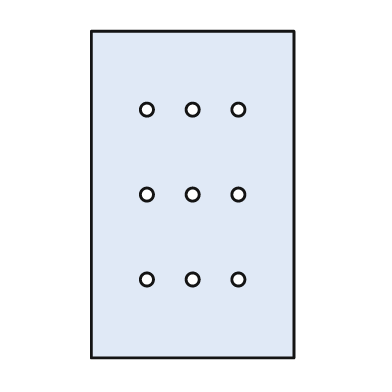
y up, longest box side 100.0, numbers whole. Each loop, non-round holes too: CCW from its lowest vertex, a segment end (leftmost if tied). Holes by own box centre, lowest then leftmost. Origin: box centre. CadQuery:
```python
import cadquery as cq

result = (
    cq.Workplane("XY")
    .moveTo(-31.0, -50.0)
    .lineTo(31.0, -50.0)
    .lineTo(31.0, 50.0)
    .lineTo(-31.0, 50.0)
    .close()
    .moveTo(-14.0, -26.0)
    .circle(2.0)
    .moveTo(0.0, -26.0)
    .circle(2.0)
    .moveTo(14.0, -26.0)
    .circle(2.0)
    .moveTo(-14.0, 0.0)
    .circle(2.0)
    .moveTo(0.0, 0.0)
    .circle(2.0)
    .moveTo(14.0, 0.0)
    .circle(2.0)
    .moveTo(-14.0, 26.0)
    .circle(2.0)
    .moveTo(0.0, 26.0)
    .circle(2.0)
    .moveTo(14.0, 26.0)
    .circle(2.0)
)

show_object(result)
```